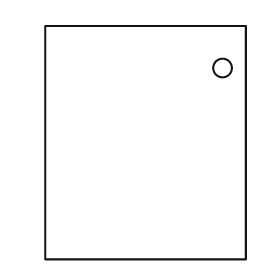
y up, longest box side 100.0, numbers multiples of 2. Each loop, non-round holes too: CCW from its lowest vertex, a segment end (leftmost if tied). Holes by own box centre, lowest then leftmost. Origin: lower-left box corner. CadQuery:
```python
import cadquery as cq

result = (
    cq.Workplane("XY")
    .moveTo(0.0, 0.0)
    .lineTo(86.0, 0.0)
    .lineTo(86.0, 100.0)
    .lineTo(0.0, 100.0)
    .close()
    .moveTo(76.0, 82.0)
    .circle(4.0)
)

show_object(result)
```